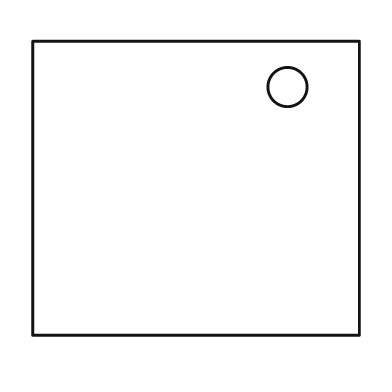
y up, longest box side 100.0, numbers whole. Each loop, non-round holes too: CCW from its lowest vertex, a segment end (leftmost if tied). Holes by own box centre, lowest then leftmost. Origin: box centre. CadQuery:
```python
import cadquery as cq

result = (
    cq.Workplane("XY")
    .moveTo(-50.0, -45.0)
    .lineTo(50.0, -45.0)
    .lineTo(50.0, 45.0)
    .lineTo(-50.0, 45.0)
    .close()
    .moveTo(28.0, 31.0)
    .circle(6.0)
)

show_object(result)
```